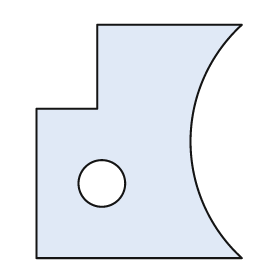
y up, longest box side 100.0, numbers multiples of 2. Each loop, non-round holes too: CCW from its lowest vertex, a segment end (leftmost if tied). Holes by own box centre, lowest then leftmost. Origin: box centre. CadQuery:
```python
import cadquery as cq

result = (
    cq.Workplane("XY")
    .moveTo(-44.0, -50.0)
    .lineTo(44.0, -50.0)
    .threePointArc((22.0, 0.0), (44.0, 50.0))
    .lineTo(-18.0, 50.0)
    .lineTo(-18.0, 14.0)
    .lineTo(-44.0, 14.0)
    .close()
    .moveTo(-16.0, -18.0)
    .circle(10.0)
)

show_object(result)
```